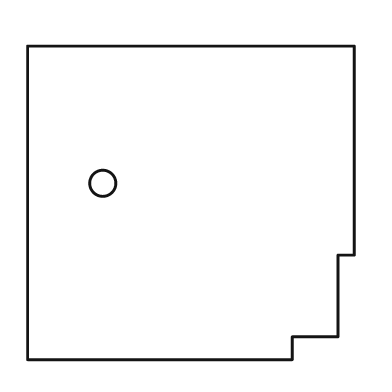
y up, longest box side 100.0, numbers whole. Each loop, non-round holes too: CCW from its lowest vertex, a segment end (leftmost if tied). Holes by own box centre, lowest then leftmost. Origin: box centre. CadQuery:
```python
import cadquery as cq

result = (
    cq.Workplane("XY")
    .moveTo(-50.0, -48.0)
    .lineTo(31.0, -48.0)
    .lineTo(31.0, -41.0)
    .lineTo(45.0, -41.0)
    .lineTo(45.0, -16.0)
    .lineTo(50.0, -16.0)
    .lineTo(50.0, 48.0)
    .lineTo(-50.0, 48.0)
    .close()
    .moveTo(-27.0, 6.0)
    .circle(4.0)
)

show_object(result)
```